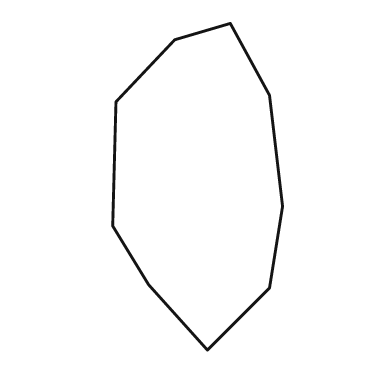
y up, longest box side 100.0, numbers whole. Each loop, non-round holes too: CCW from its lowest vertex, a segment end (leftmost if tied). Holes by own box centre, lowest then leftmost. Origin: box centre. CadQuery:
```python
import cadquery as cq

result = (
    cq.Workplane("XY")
    .moveTo(3.0, -50.0)
    .lineTo(22.0, -31.0)
    .lineTo(26.0, -6.0)
    .lineTo(22.0, 28.0)
    .lineTo(10.0, 50.0)
    .lineTo(-7.0, 45.0)
    .lineTo(-25.0, 26.0)
    .lineTo(-26.0, -12.0)
    .lineTo(-15.0, -30.0)
    .close()
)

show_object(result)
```